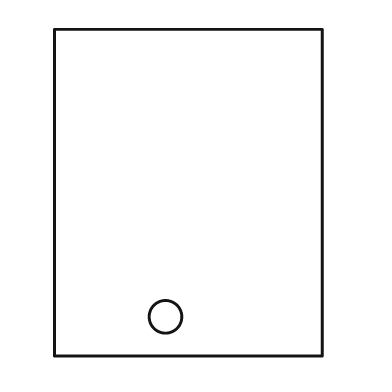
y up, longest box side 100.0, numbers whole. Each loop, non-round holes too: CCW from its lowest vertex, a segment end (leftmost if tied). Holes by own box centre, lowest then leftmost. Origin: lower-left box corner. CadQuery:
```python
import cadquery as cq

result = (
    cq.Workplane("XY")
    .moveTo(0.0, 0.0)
    .lineTo(82.0, 0.0)
    .lineTo(82.0, 100.0)
    .lineTo(0.0, 100.0)
    .close()
    .moveTo(34.0, 12.0)
    .circle(5.0)
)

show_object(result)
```